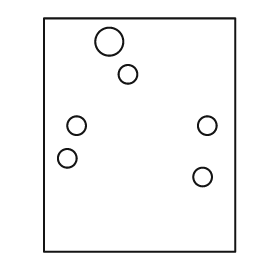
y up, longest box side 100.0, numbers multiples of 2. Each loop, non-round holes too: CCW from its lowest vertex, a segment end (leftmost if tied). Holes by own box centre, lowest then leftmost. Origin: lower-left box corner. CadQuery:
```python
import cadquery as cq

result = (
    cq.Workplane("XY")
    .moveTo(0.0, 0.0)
    .lineTo(82.0, 0.0)
    .lineTo(82.0, 100.0)
    .lineTo(0.0, 100.0)
    .close()
    .moveTo(68.0, 32.0)
    .circle(4.0)
    .moveTo(10.0, 40.0)
    .circle(4.0)
    .moveTo(14.0, 54.0)
    .circle(4.0)
    .moveTo(70.0, 54.0)
    .circle(4.0)
    .moveTo(36.0, 76.0)
    .circle(4.0)
    .moveTo(28.0, 90.0)
    .circle(6.0)
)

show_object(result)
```